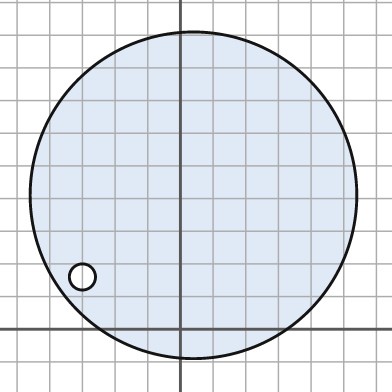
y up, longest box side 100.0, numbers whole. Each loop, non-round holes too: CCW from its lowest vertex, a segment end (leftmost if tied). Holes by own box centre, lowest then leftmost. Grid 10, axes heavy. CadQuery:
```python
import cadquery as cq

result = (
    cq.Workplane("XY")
    .moveTo(4.0, 41.0)
    .circle(50.0)
    .moveTo(-30.0, 16.0)
    .circle(4.0)
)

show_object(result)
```